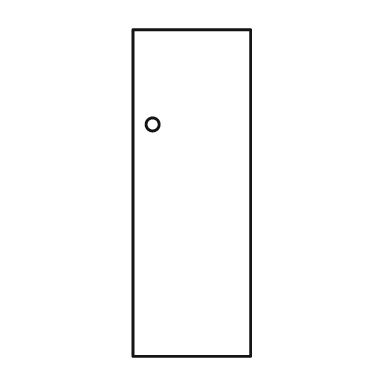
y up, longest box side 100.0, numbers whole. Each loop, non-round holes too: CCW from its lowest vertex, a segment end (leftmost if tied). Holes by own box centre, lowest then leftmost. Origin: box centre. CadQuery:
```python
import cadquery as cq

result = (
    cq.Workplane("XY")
    .moveTo(-18.0, -50.0)
    .lineTo(18.0, -50.0)
    .lineTo(18.0, 50.0)
    .lineTo(-18.0, 50.0)
    .close()
    .moveTo(-12.0, 21.0)
    .circle(2.0)
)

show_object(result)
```